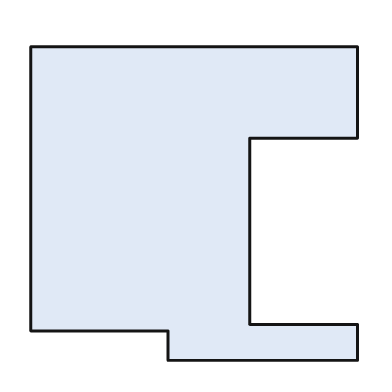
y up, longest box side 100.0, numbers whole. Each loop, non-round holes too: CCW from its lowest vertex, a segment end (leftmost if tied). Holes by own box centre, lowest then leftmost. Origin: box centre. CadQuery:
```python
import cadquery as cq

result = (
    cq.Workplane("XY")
    .moveTo(-8.0, -48.0)
    .lineTo(50.0, -48.0)
    .lineTo(50.0, -37.0)
    .lineTo(17.0, -37.0)
    .lineTo(17.0, 20.0)
    .lineTo(50.0, 20.0)
    .lineTo(50.0, 48.0)
    .lineTo(-50.0, 48.0)
    .lineTo(-50.0, -39.0)
    .lineTo(-8.0, -39.0)
    .close()
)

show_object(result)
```